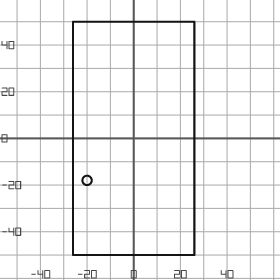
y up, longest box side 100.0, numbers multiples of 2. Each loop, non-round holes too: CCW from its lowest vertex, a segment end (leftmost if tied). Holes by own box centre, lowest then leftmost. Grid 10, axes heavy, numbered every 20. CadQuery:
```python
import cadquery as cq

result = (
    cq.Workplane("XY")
    .moveTo(-26.0, -50.0)
    .lineTo(26.0, -50.0)
    .lineTo(26.0, 50.0)
    .lineTo(-26.0, 50.0)
    .close()
    .moveTo(-20.0, -18.0)
    .circle(2.0)
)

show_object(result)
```